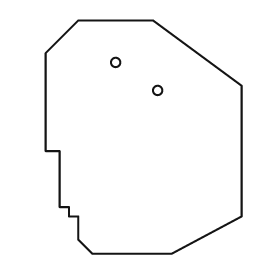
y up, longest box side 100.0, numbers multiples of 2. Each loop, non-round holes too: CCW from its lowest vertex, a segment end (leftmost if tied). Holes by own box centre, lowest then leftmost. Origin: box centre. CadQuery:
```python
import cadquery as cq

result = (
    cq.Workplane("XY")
    .moveTo(-22.0, -50.0)
    .lineTo(12.0, -50.0)
    .lineTo(42.0, -34.0)
    .lineTo(42.0, 22.0)
    .lineTo(4.0, 50.0)
    .lineTo(-28.0, 50.0)
    .lineTo(-42.0, 36.0)
    .lineTo(-42.0, -6.0)
    .lineTo(-36.0, -6.0)
    .lineTo(-36.0, -30.0)
    .lineTo(-32.0, -30.0)
    .lineTo(-32.0, -34.0)
    .lineTo(-28.0, -34.0)
    .lineTo(-28.0, -44.0)
    .close()
    .moveTo(6.0, 20.0)
    .circle(2.0)
    .moveTo(-12.0, 32.0)
    .circle(2.0)
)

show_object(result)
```